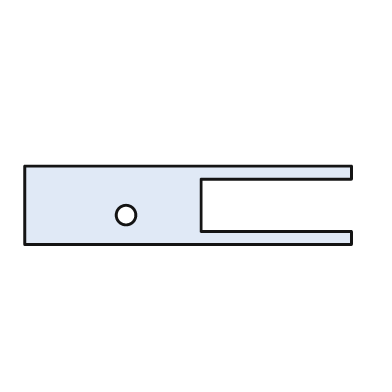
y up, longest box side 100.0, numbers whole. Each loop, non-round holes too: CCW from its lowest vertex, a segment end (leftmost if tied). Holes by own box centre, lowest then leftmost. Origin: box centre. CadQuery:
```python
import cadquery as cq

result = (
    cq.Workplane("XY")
    .moveTo(-50.0, -12.0)
    .lineTo(50.0, -12.0)
    .lineTo(50.0, -8.0)
    .lineTo(4.0, -8.0)
    .lineTo(4.0, 8.0)
    .lineTo(50.0, 8.0)
    .lineTo(50.0, 12.0)
    .lineTo(-50.0, 12.0)
    .close()
    .moveTo(-19.0, -3.0)
    .circle(3.0)
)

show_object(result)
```